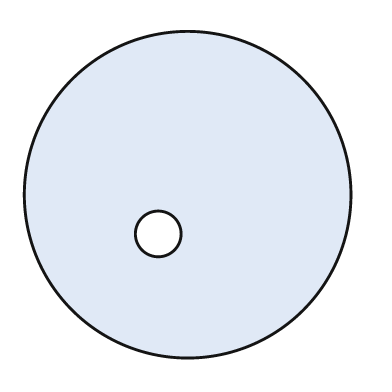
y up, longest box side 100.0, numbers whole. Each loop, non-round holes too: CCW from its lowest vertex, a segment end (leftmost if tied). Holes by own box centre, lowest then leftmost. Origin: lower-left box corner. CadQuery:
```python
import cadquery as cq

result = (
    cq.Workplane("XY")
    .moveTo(50.0, 50.0)
    .circle(50.0)
    .moveTo(41.0, 38.0)
    .circle(7.0)
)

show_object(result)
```